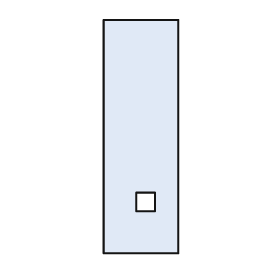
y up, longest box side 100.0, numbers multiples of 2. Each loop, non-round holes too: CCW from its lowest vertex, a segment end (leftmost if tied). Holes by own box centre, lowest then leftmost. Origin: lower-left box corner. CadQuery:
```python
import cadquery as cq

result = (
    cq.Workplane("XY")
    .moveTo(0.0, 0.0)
    .lineTo(32.0, 0.0)
    .lineTo(32.0, 100.0)
    .lineTo(0.0, 100.0)
    .close()
    .moveTo(14.0, 18.0)
    .lineTo(22.0, 18.0)
    .lineTo(22.0, 26.0)
    .lineTo(14.0, 26.0)
    .close()
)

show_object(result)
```